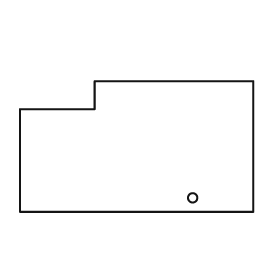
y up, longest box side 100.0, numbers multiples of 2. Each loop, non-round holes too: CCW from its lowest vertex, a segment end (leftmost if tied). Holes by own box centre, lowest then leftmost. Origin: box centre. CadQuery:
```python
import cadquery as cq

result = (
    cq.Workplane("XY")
    .moveTo(-50.0, -28.0)
    .lineTo(50.0, -28.0)
    .lineTo(50.0, 28.0)
    .lineTo(-18.0, 28.0)
    .lineTo(-18.0, 16.0)
    .lineTo(-50.0, 16.0)
    .close()
    .moveTo(24.0, -22.0)
    .circle(2.0)
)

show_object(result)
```